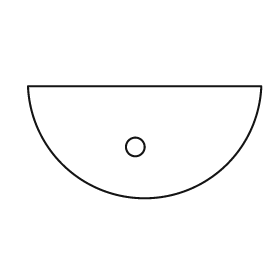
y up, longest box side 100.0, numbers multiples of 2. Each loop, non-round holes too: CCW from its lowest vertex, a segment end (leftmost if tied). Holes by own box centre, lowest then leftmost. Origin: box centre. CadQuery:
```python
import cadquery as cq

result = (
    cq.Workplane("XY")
    .moveTo(-50.0, 24.0)
    .threePointArc((0.0, -24.0), (50.0, 24.0))
    .close()
    .moveTo(-4.0, -2.0)
    .circle(4.0)
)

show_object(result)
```